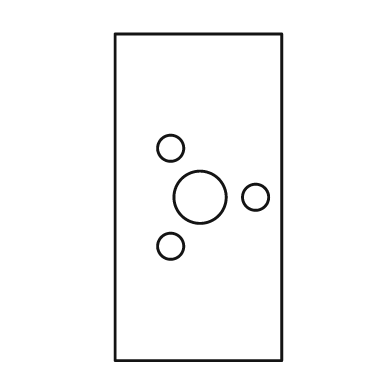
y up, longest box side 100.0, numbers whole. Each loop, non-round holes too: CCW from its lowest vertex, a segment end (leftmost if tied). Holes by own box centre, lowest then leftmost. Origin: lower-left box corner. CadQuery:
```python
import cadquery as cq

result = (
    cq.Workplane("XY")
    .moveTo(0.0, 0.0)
    .lineTo(51.0, 0.0)
    .lineTo(51.0, 100.0)
    .lineTo(0.0, 100.0)
    .close()
    .moveTo(17.0, 35.0)
    .circle(4.0)
    .moveTo(26.0, 50.0)
    .circle(8.0)
    .moveTo(43.0, 50.0)
    .circle(4.0)
    .moveTo(17.0, 65.0)
    .circle(4.0)
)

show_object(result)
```